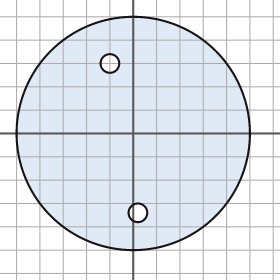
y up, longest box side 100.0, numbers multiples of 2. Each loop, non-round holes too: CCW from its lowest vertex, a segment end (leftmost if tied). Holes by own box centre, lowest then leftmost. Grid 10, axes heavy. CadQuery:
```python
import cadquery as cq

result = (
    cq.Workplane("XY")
    .moveTo(0.0, 0.0)
    .circle(50.0)
    .moveTo(2.0, -34.0)
    .circle(4.0)
    .moveTo(-10.0, 30.0)
    .circle(4.0)
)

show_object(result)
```